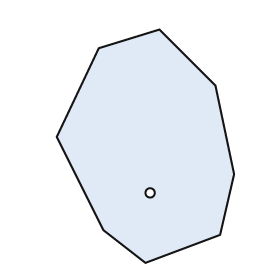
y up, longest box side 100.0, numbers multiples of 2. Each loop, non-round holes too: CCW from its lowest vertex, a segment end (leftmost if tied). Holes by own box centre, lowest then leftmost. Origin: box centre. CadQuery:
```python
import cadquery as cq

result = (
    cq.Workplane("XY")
    .moveTo(0.0, -50.0)
    .lineTo(32.0, -38.0)
    .lineTo(38.0, -12.0)
    .lineTo(30.0, 26.0)
    .lineTo(6.0, 50.0)
    .lineTo(-20.0, 42.0)
    .lineTo(-38.0, 4.0)
    .lineTo(-18.0, -36.0)
    .close()
    .moveTo(2.0, -20.0)
    .circle(2.0)
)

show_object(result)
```